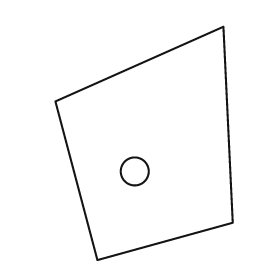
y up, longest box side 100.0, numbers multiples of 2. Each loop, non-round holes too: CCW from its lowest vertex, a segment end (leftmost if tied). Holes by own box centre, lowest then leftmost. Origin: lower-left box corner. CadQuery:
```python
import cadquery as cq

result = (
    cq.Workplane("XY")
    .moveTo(18.0, 0.0)
    .lineTo(76.0, 16.0)
    .lineTo(72.0, 100.0)
    .lineTo(0.0, 68.0)
    .close()
    .moveTo(34.0, 38.0)
    .circle(6.0)
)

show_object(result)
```